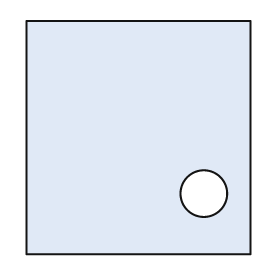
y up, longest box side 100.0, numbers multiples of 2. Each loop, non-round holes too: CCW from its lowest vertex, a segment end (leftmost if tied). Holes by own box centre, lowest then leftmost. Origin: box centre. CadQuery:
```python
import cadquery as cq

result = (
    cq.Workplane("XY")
    .moveTo(-48.0, -50.0)
    .lineTo(48.0, -50.0)
    .lineTo(48.0, 50.0)
    .lineTo(-48.0, 50.0)
    .close()
    .moveTo(28.0, -24.0)
    .circle(10.0)
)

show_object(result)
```